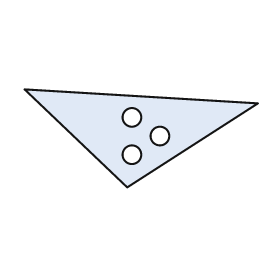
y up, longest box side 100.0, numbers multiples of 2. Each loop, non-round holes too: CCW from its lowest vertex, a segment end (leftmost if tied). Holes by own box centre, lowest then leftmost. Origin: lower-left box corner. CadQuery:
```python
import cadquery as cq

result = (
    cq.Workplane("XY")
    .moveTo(44.0, 0.0)
    .lineTo(100.0, 36.0)
    .lineTo(0.0, 42.0)
    .close()
    .moveTo(46.0, 14.0)
    .circle(4.0)
    .moveTo(58.0, 22.0)
    .circle(4.0)
    .moveTo(46.0, 30.0)
    .circle(4.0)
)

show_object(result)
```